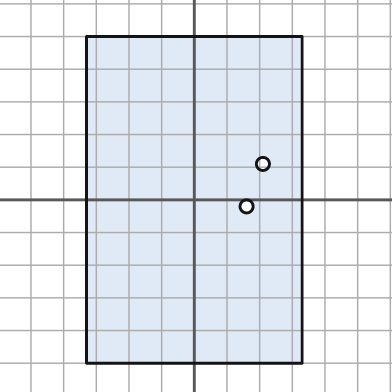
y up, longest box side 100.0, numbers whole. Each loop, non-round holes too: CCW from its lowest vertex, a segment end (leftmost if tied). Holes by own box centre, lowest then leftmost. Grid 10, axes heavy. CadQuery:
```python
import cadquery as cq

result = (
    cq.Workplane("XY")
    .moveTo(-33.0, -50.0)
    .lineTo(33.0, -50.0)
    .lineTo(33.0, 50.0)
    .lineTo(-33.0, 50.0)
    .close()
    .moveTo(16.0, -2.0)
    .circle(2.0)
    .moveTo(21.0, 11.0)
    .circle(2.0)
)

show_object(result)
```